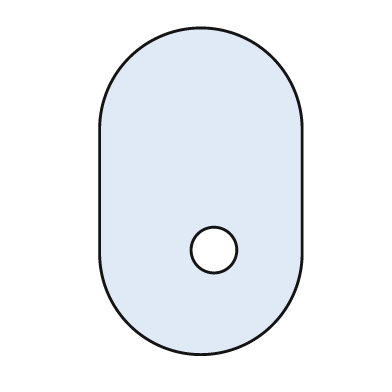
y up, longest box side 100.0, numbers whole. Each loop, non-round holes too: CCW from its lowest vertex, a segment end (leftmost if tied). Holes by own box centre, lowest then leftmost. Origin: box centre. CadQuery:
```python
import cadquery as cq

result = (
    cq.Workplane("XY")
    .moveTo(-31.0, -19.0)
    .threePointArc((0.0, -50.0), (31.0, -19.0))
    .lineTo(31.0, 19.0)
    .threePointArc((0.0, 50.0), (-31.0, 19.0))
    .close()
    .moveTo(4.0, -18.0)
    .circle(7.0)
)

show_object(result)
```